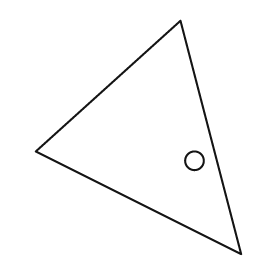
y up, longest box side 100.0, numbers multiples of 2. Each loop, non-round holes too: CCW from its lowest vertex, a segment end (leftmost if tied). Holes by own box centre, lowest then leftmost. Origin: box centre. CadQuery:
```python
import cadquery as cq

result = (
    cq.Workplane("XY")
    .moveTo(44.0, -50.0)
    .lineTo(18.0, 50.0)
    .lineTo(-44.0, -6.0)
    .close()
    .moveTo(24.0, -10.0)
    .circle(4.0)
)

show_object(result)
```